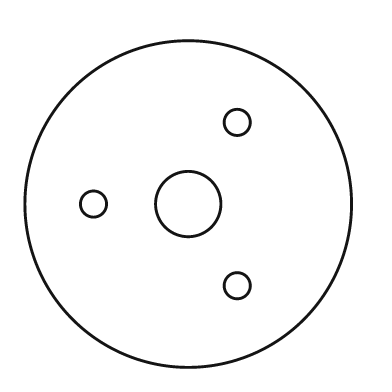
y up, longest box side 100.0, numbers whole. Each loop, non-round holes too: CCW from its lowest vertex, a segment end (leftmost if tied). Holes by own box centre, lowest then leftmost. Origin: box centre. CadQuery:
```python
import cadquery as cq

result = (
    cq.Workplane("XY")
    .moveTo(0.0, 0.0)
    .circle(50.0)
    .moveTo(15.0, -25.0)
    .circle(4.0)
    .moveTo(-29.0, 0.0)
    .circle(4.0)
    .moveTo(0.0, 0.0)
    .circle(10.0)
    .moveTo(15.0, 25.0)
    .circle(4.0)
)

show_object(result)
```